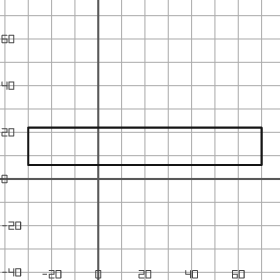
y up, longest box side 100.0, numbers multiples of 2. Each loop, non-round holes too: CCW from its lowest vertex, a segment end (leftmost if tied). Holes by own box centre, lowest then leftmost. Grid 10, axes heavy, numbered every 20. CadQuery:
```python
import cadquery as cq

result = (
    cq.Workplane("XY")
    .moveTo(-30.0, 6.0)
    .lineTo(70.0, 6.0)
    .lineTo(70.0, 22.0)
    .lineTo(-30.0, 22.0)
    .close()
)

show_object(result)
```